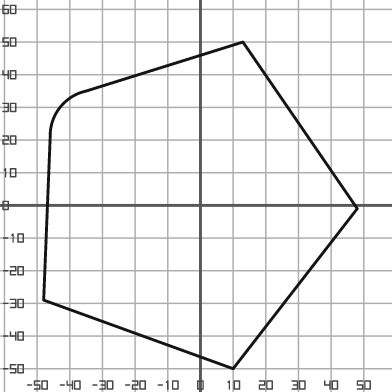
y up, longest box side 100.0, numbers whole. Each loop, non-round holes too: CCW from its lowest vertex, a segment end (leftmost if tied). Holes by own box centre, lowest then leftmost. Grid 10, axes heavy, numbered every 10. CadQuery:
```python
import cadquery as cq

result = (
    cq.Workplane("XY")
    .moveTo(10.0, -50.0)
    .lineTo(48.0, -1.0)
    .lineTo(13.0, 50.0)
    .lineTo(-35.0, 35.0)
    .threePointArc((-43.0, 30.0), (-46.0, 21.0))
    .lineTo(-48.0, -29.0)
    .close()
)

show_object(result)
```